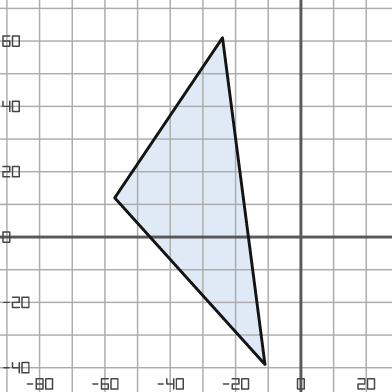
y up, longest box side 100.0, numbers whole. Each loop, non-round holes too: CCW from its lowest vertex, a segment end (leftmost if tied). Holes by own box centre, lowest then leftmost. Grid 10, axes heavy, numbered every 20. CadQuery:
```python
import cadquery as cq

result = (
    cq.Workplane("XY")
    .moveTo(-11.0, -39.0)
    .lineTo(-24.0, 61.0)
    .lineTo(-57.0, 12.0)
    .close()
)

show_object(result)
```